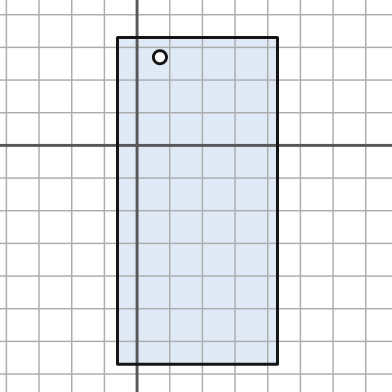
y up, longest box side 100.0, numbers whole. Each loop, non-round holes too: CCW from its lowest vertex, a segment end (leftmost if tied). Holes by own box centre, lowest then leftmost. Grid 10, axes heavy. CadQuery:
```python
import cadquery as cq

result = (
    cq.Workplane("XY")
    .moveTo(-6.0, -67.0)
    .lineTo(43.0, -67.0)
    .lineTo(43.0, 33.0)
    .lineTo(-6.0, 33.0)
    .close()
    .moveTo(7.0, 27.0)
    .circle(2.0)
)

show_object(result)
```